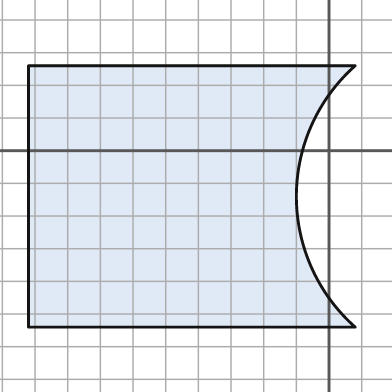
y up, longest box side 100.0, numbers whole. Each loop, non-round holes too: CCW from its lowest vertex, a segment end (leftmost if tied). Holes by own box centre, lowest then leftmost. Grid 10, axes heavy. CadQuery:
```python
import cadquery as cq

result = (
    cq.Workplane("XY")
    .moveTo(-92.0, -54.0)
    .lineTo(8.0, -54.0)
    .threePointArc((-10.0, -14.0), (8.0, 26.0))
    .lineTo(-92.0, 26.0)
    .close()
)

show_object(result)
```